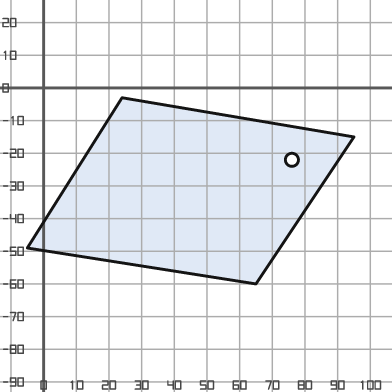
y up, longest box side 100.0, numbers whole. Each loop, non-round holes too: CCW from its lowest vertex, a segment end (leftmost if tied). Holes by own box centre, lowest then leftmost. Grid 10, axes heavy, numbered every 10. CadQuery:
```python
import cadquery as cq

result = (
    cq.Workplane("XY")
    .moveTo(65.0, -60.0)
    .lineTo(95.0, -15.0)
    .lineTo(24.0, -3.0)
    .lineTo(-5.0, -49.0)
    .close()
    .moveTo(76.0, -22.0)
    .circle(2.0)
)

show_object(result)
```